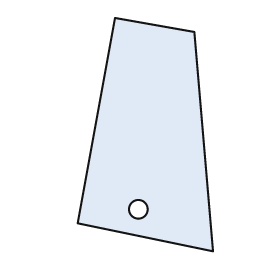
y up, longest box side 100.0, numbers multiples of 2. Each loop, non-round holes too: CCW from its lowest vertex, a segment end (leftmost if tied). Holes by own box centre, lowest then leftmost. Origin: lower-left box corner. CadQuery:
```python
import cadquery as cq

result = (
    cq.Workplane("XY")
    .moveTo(58.0, 0.0)
    .lineTo(50.0, 94.0)
    .lineTo(16.0, 100.0)
    .lineTo(0.0, 12.0)
    .close()
    .moveTo(26.0, 18.0)
    .circle(4.0)
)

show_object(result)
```